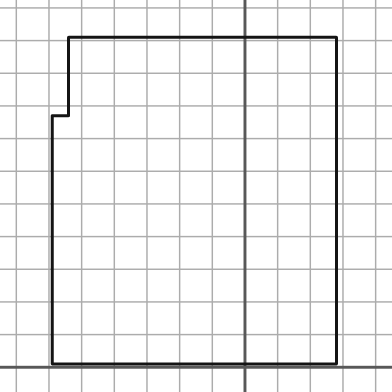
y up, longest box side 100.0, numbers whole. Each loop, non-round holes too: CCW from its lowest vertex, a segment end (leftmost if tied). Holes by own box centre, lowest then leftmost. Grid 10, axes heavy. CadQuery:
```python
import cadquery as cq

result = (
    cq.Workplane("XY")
    .moveTo(-59.0, 1.0)
    .lineTo(28.0, 1.0)
    .lineTo(28.0, 101.0)
    .lineTo(-54.0, 101.0)
    .lineTo(-54.0, 77.0)
    .lineTo(-59.0, 77.0)
    .close()
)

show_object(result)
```